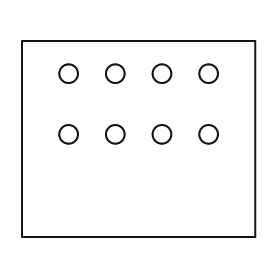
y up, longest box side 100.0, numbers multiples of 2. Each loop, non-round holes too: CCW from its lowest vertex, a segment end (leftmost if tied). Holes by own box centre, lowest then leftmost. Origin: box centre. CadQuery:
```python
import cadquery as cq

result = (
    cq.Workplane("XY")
    .moveTo(-50.0, -42.0)
    .lineTo(50.0, -42.0)
    .lineTo(50.0, 42.0)
    .lineTo(-50.0, 42.0)
    .close()
    .moveTo(-30.0, 2.0)
    .circle(4.0)
    .moveTo(-10.0, 2.0)
    .circle(4.0)
    .moveTo(10.0, 2.0)
    .circle(4.0)
    .moveTo(30.0, 2.0)
    .circle(4.0)
    .moveTo(-30.0, 28.0)
    .circle(4.0)
    .moveTo(-10.0, 28.0)
    .circle(4.0)
    .moveTo(10.0, 28.0)
    .circle(4.0)
    .moveTo(30.0, 28.0)
    .circle(4.0)
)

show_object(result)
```